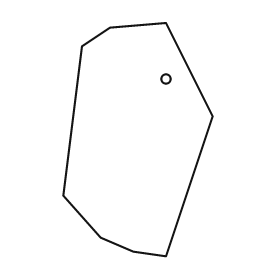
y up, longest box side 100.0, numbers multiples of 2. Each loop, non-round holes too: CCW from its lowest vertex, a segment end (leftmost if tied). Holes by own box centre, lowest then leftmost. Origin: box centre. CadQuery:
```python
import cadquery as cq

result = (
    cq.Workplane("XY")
    .moveTo(12.0, -50.0)
    .lineTo(32.0, 10.0)
    .lineTo(12.0, 50.0)
    .lineTo(-12.0, 48.0)
    .lineTo(-24.0, 40.0)
    .lineTo(-32.0, -24.0)
    .lineTo(-16.0, -42.0)
    .lineTo(-2.0, -48.0)
    .close()
    .moveTo(12.0, 26.0)
    .circle(2.0)
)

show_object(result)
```